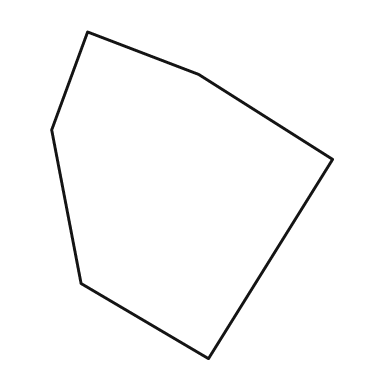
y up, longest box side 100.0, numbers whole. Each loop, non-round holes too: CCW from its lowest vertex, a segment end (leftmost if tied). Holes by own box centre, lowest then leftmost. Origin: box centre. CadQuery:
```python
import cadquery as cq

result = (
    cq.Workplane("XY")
    .moveTo(5.0, -50.0)
    .lineTo(43.0, 11.0)
    .lineTo(2.0, 37.0)
    .lineTo(-32.0, 50.0)
    .lineTo(-43.0, 20.0)
    .lineTo(-34.0, -27.0)
    .close()
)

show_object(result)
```